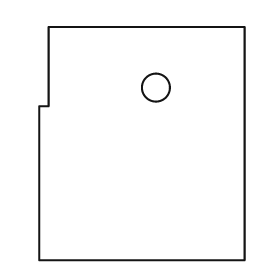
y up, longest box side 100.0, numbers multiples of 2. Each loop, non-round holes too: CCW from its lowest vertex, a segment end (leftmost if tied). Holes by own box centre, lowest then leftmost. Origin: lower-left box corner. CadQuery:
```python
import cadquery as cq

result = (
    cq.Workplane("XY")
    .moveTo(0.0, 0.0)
    .lineTo(88.0, 0.0)
    .lineTo(88.0, 100.0)
    .lineTo(4.0, 100.0)
    .lineTo(4.0, 66.0)
    .lineTo(0.0, 66.0)
    .close()
    .moveTo(50.0, 74.0)
    .circle(6.0)
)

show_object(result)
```